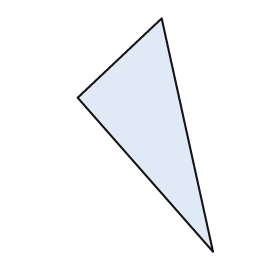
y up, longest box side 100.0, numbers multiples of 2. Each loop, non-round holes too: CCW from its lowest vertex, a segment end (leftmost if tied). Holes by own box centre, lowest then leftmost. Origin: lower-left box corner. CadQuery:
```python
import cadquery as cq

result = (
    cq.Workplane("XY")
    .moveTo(58.0, 0.0)
    .lineTo(36.0, 100.0)
    .lineTo(0.0, 66.0)
    .close()
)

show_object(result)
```